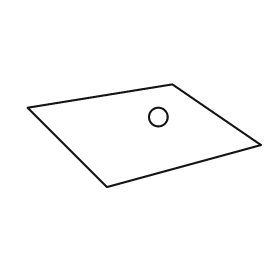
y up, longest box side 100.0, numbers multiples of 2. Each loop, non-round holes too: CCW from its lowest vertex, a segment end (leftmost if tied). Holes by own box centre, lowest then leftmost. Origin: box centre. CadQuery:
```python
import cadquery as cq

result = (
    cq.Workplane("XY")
    .moveTo(-16.0, -22.0)
    .lineTo(50.0, -4.0)
    .lineTo(12.0, 22.0)
    .lineTo(-50.0, 12.0)
    .close()
    .moveTo(6.0, 8.0)
    .circle(4.0)
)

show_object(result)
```